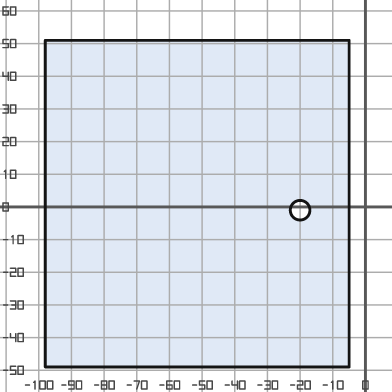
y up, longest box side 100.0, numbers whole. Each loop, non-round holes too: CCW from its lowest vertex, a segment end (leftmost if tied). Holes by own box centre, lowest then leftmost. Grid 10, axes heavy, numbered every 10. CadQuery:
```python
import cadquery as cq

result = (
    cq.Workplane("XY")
    .moveTo(-98.0, -49.0)
    .lineTo(-5.0, -49.0)
    .lineTo(-5.0, 51.0)
    .lineTo(-98.0, 51.0)
    .close()
    .moveTo(-20.0, -1.0)
    .circle(3.0)
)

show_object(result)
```